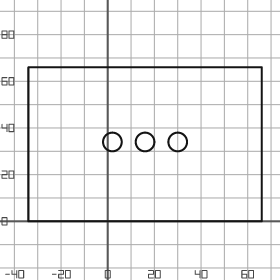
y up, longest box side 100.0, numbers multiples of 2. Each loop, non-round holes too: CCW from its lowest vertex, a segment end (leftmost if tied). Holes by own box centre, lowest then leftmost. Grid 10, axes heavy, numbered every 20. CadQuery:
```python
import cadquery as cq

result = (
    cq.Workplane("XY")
    .moveTo(-34.0, 0.0)
    .lineTo(66.0, 0.0)
    .lineTo(66.0, 66.0)
    .lineTo(-34.0, 66.0)
    .close()
    .moveTo(2.0, 34.0)
    .circle(4.0)
    .moveTo(16.0, 34.0)
    .circle(4.0)
    .moveTo(30.0, 34.0)
    .circle(4.0)
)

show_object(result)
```